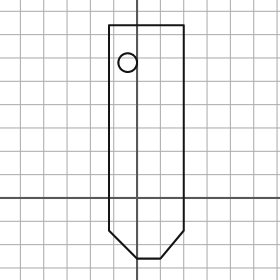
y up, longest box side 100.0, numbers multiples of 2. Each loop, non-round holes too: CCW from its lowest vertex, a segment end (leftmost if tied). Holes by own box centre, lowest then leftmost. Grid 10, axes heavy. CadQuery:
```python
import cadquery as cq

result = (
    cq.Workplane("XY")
    .moveTo(0.0, -26.0)
    .lineTo(10.0, -26.0)
    .lineTo(20.0, -14.0)
    .lineTo(20.0, 74.0)
    .lineTo(-12.0, 74.0)
    .lineTo(-12.0, -14.0)
    .close()
    .moveTo(-4.0, 58.0)
    .circle(4.0)
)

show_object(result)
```